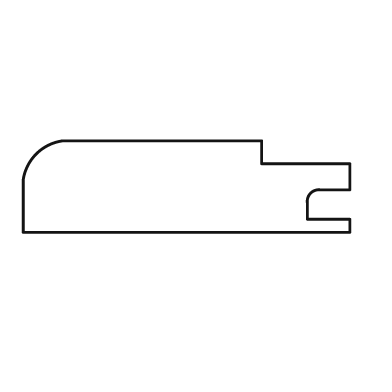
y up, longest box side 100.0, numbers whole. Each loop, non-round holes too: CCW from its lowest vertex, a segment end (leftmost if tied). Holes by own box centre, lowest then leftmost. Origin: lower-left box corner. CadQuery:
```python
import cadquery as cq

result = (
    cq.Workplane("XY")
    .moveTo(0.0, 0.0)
    .lineTo(100.0, 0.0)
    .lineTo(100.0, 4.0)
    .lineTo(87.0, 4.0)
    .lineTo(87.0, 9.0)
    .threePointArc((88.0, 12.0), (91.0, 13.0))
    .lineTo(100.0, 13.0)
    .lineTo(100.0, 21.0)
    .lineTo(73.0, 21.0)
    .lineTo(73.0, 28.0)
    .lineTo(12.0, 28.0)
    .threePointArc((4.0, 24.0), (0.0, 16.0))
    .close()
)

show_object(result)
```